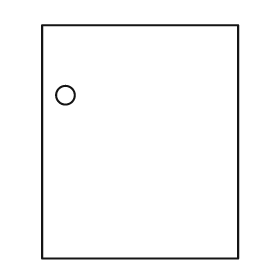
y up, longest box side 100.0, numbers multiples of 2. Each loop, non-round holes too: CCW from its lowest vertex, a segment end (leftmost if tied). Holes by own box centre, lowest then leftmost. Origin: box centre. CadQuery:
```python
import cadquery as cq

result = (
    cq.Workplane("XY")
    .moveTo(-42.0, -50.0)
    .lineTo(42.0, -50.0)
    .lineTo(42.0, 50.0)
    .lineTo(-42.0, 50.0)
    .close()
    .moveTo(-32.0, 20.0)
    .circle(4.0)
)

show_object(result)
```